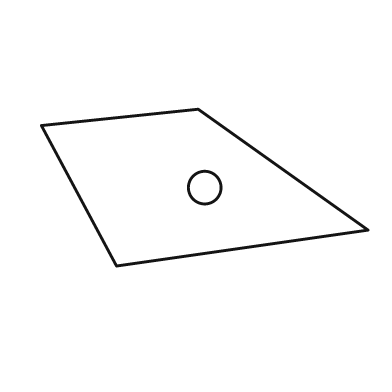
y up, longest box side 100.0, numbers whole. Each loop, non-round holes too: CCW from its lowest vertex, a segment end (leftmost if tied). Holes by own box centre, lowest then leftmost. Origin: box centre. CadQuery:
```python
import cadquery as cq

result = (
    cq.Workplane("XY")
    .moveTo(-27.0, -24.0)
    .lineTo(50.0, -13.0)
    .lineTo(-2.0, 24.0)
    .lineTo(-50.0, 19.0)
    .close()
    .moveTo(0.0, 0.0)
    .circle(5.0)
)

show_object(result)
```